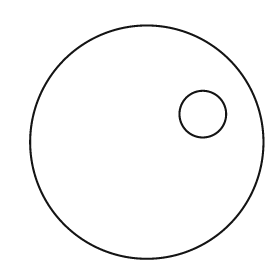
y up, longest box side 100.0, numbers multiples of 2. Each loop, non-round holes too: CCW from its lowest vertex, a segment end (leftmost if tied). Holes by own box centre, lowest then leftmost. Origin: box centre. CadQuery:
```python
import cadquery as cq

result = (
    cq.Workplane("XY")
    .moveTo(0.0, 0.0)
    .circle(50.0)
    .moveTo(24.0, 12.0)
    .circle(10.0)
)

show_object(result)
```